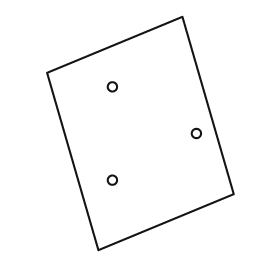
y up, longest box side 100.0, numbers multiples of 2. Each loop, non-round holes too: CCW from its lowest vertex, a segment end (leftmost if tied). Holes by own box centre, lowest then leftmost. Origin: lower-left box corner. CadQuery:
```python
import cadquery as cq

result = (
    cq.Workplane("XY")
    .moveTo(22.0, 0.0)
    .lineTo(80.0, 24.0)
    .lineTo(58.0, 100.0)
    .lineTo(0.0, 76.0)
    .close()
    .moveTo(28.0, 30.0)
    .circle(2.0)
    .moveTo(64.0, 50.0)
    .circle(2.0)
    .moveTo(28.0, 70.0)
    .circle(2.0)
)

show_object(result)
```